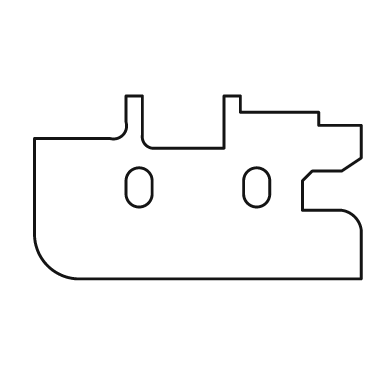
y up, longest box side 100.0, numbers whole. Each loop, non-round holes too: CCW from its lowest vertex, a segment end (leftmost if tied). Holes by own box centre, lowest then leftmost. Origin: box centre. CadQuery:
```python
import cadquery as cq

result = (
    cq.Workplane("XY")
    .moveTo(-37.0, -28.0)
    .lineTo(50.0, -28.0)
    .lineTo(50.0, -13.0)
    .threePointArc((48.0, -9.0), (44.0, -7.0))
    .lineTo(32.0, -7.0)
    .lineTo(32.0, 2.0)
    .lineTo(35.0, 5.0)
    .lineTo(44.0, 5.0)
    .lineTo(50.0, 9.0)
    .lineTo(50.0, 19.0)
    .lineTo(37.0, 19.0)
    .lineTo(37.0, 23.0)
    .lineTo(13.0, 23.0)
    .lineTo(13.0, 28.0)
    .lineTo(8.0, 28.0)
    .lineTo(8.0, 12.0)
    .lineTo(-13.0, 12.0)
    .threePointArc((-16.0, 13.0), (-17.0, 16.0))
    .lineTo(-17.0, 28.0)
    .lineTo(-22.0, 28.0)
    .lineTo(-22.0, 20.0)
    .threePointArc((-23.0, 16.0), (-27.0, 15.0))
    .lineTo(-50.0, 15.0)
    .lineTo(-50.0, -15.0)
    .threePointArc((-46.0, -24.0), (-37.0, -28.0))
    .close()
    .moveTo(-22.0, -2.0)
    .threePointArc((-18.0, -6.0), (-14.0, -2.0))
    .lineTo(-14.0, 2.0)
    .threePointArc((-18.0, 6.0), (-22.0, 2.0))
    .close()
    .moveTo(14.0, -2.0)
    .threePointArc((18.0, -6.0), (22.0, -2.0))
    .lineTo(22.0, 2.0)
    .threePointArc((18.0, 6.0), (14.0, 2.0))
    .close()
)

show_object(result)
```